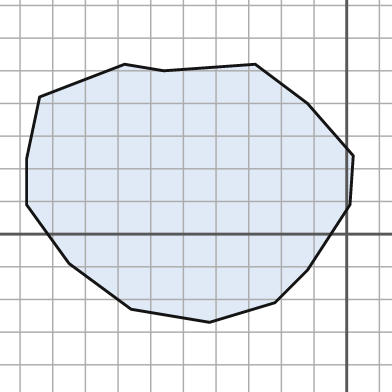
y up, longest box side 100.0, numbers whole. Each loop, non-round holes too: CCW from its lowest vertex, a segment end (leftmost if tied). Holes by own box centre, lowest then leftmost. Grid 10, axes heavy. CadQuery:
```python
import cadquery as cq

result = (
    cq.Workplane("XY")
    .moveTo(-42.0, -27.0)
    .lineTo(-22.0, -21.0)
    .lineTo(-12.0, -11.0)
    .lineTo(1.0, 9.0)
    .lineTo(2.0, 24.0)
    .lineTo(-12.0, 40.0)
    .lineTo(-28.0, 52.0)
    .lineTo(-56.0, 50.0)
    .lineTo(-68.0, 52.0)
    .lineTo(-94.0, 42.0)
    .lineTo(-98.0, 23.0)
    .lineTo(-98.0, 9.0)
    .lineTo(-85.0, -9.0)
    .lineTo(-66.0, -23.0)
    .close()
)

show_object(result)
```